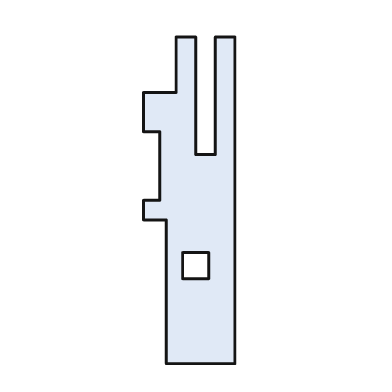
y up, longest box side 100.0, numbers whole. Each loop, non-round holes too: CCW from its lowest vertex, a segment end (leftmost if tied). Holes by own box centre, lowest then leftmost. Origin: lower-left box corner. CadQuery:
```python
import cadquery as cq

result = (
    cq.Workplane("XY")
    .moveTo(7.0, 0.0)
    .lineTo(28.0, 0.0)
    .lineTo(28.0, 100.0)
    .lineTo(22.0, 100.0)
    .lineTo(22.0, 64.0)
    .lineTo(16.0, 64.0)
    .lineTo(16.0, 100.0)
    .lineTo(10.0, 100.0)
    .lineTo(10.0, 83.0)
    .lineTo(0.0, 83.0)
    .lineTo(0.0, 71.0)
    .lineTo(5.0, 71.0)
    .lineTo(5.0, 50.0)
    .lineTo(0.0, 50.0)
    .lineTo(0.0, 44.0)
    .lineTo(7.0, 44.0)
    .close()
    .moveTo(12.0, 26.0)
    .lineTo(20.0, 26.0)
    .lineTo(20.0, 34.0)
    .lineTo(12.0, 34.0)
    .close()
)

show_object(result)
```